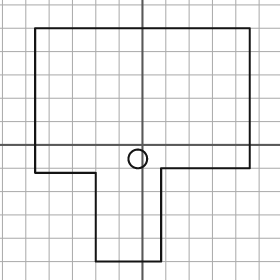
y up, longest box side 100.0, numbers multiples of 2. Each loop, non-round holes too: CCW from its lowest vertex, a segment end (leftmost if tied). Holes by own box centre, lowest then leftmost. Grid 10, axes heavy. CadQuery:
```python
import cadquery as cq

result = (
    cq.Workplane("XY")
    .moveTo(-20.0, -50.0)
    .lineTo(8.0, -50.0)
    .lineTo(8.0, -10.0)
    .lineTo(46.0, -10.0)
    .lineTo(46.0, 50.0)
    .lineTo(-46.0, 50.0)
    .lineTo(-46.0, -12.0)
    .lineTo(-20.0, -12.0)
    .close()
    .moveTo(-2.0, -6.0)
    .circle(4.0)
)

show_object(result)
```